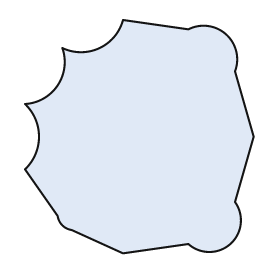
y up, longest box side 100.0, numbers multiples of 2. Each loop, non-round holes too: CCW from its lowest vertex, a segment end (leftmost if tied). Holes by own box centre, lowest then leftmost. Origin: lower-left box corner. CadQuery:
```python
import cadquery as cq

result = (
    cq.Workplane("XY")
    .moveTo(42.0, 0.0)
    .lineTo(70.0, 4.0)
    .threePointArc((88.0, 4.0), (90.0, 22.0))
    .lineTo(98.0, 50.0)
    .lineTo(90.0, 78.0)
    .threePointArc((86.0, 94.0), (70.0, 96.0))
    .lineTo(42.0, 100.0)
    .threePointArc((32.0, 88.0), (16.0, 88.0))
    .threePointArc((14.0, 72.0), (0.0, 64.0))
    .threePointArc((6.0, 50.0), (0.0, 36.0))
    .lineTo(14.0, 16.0)
    .threePointArc((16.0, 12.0), (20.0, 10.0))
    .close()
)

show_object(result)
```